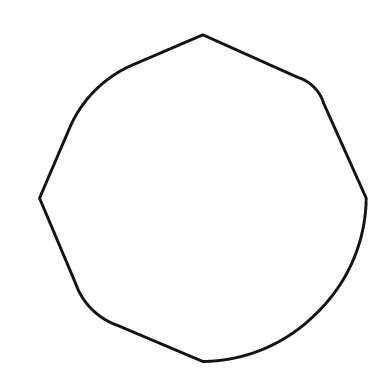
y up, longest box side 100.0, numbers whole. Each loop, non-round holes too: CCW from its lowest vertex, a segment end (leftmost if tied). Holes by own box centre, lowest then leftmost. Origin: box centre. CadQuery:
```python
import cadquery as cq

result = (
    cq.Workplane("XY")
    .moveTo(0.0, -50.0)
    .threePointArc((19.0, -46.0), (35.0, -35.0))
    .threePointArc((46.0, -19.0), (50.0, 0.0))
    .lineTo(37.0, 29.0)
    .threePointArc((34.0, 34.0), (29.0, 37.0))
    .lineTo(0.0, 50.0)
    .lineTo(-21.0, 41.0)
    .threePointArc((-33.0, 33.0), (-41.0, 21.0))
    .lineTo(-50.0, 0.0)
    .lineTo(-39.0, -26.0)
    .threePointArc((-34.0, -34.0), (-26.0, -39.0))
    .close()
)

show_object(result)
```